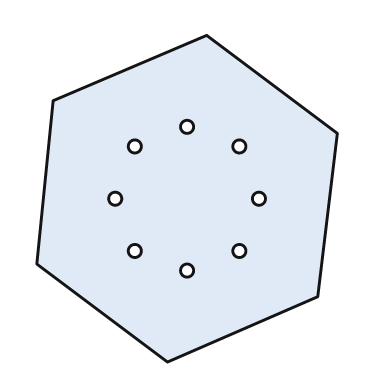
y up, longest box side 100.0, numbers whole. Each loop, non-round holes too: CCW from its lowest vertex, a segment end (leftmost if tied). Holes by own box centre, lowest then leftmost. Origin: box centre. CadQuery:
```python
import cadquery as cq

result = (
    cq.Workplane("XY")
    .moveTo(-6.0, -50.0)
    .lineTo(40.0, -30.0)
    .lineTo(46.0, 20.0)
    .lineTo(6.0, 50.0)
    .lineTo(-41.0, 30.0)
    .lineTo(-46.0, -20.0)
    .close()
    .moveTo(0.0, -22.0)
    .circle(2.0)
    .moveTo(-16.0, -16.0)
    .circle(2.0)
    .moveTo(16.0, -16.0)
    .circle(2.0)
    .moveTo(-22.0, 0.0)
    .circle(2.0)
    .moveTo(22.0, 0.0)
    .circle(2.0)
    .moveTo(-16.0, 16.0)
    .circle(2.0)
    .moveTo(16.0, 16.0)
    .circle(2.0)
    .moveTo(0.0, 22.0)
    .circle(2.0)
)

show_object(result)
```